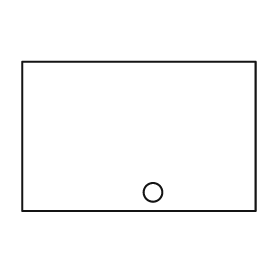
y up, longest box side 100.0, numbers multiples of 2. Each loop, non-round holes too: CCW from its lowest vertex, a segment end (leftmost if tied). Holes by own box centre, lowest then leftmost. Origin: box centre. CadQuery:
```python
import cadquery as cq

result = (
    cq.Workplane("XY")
    .moveTo(-50.0, -32.0)
    .lineTo(50.0, -32.0)
    .lineTo(50.0, 32.0)
    .lineTo(-50.0, 32.0)
    .close()
    .moveTo(6.0, -24.0)
    .circle(4.0)
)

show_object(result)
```